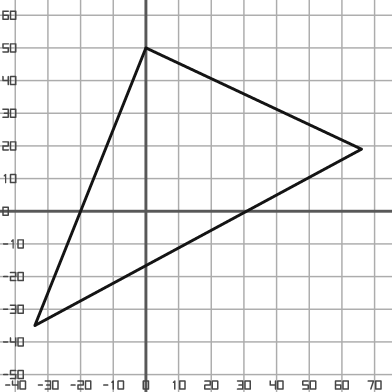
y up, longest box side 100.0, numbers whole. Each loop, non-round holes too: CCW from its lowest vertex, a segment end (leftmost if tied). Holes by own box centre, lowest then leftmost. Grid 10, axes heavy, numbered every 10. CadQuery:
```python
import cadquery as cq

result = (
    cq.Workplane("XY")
    .moveTo(-34.0, -35.0)
    .lineTo(66.0, 19.0)
    .lineTo(0.0, 50.0)
    .close()
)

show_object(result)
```